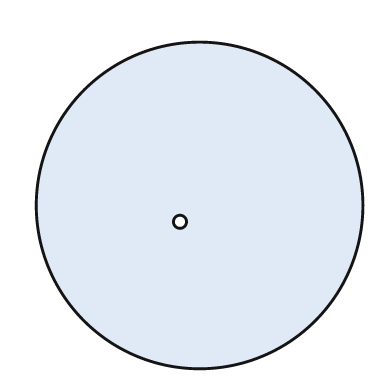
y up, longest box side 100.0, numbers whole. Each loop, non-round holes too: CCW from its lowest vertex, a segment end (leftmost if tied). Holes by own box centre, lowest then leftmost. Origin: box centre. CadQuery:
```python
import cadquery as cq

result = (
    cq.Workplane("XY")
    .moveTo(0.0, 0.0)
    .circle(50.0)
    .moveTo(-6.0, -5.0)
    .circle(2.0)
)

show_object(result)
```